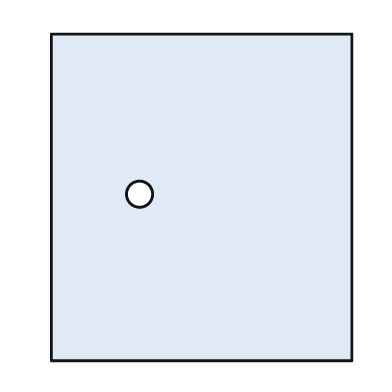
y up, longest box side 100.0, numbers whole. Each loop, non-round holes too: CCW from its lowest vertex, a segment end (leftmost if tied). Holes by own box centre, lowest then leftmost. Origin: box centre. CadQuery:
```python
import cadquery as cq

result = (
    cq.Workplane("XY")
    .moveTo(-46.0, -50.0)
    .lineTo(46.0, -50.0)
    .lineTo(46.0, 50.0)
    .lineTo(-46.0, 50.0)
    .close()
    .moveTo(-19.0, 1.0)
    .circle(4.0)
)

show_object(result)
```